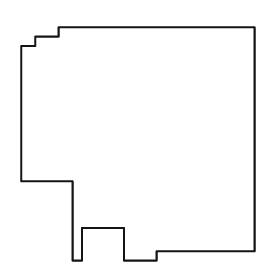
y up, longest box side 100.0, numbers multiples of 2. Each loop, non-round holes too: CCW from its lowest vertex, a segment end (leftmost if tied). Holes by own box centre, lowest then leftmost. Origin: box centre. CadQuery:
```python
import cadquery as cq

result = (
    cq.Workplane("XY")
    .moveTo(-28.0, -50.0)
    .lineTo(-24.0, -50.0)
    .lineTo(-24.0, -36.0)
    .lineTo(-6.0, -36.0)
    .lineTo(-6.0, -50.0)
    .lineTo(8.0, -50.0)
    .lineTo(8.0, -46.0)
    .lineTo(50.0, -46.0)
    .lineTo(50.0, 50.0)
    .lineTo(-34.0, 50.0)
    .lineTo(-34.0, 46.0)
    .lineTo(-44.0, 46.0)
    .lineTo(-44.0, 42.0)
    .lineTo(-50.0, 42.0)
    .lineTo(-50.0, -16.0)
    .lineTo(-28.0, -16.0)
    .close()
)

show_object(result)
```